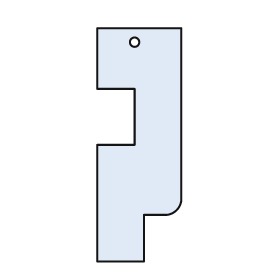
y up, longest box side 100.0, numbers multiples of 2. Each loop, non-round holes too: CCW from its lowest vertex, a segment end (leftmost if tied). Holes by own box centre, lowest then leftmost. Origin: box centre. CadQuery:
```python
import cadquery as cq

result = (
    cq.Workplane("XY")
    .moveTo(-18.0, -50.0)
    .lineTo(2.0, -50.0)
    .lineTo(2.0, -30.0)
    .lineTo(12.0, -30.0)
    .threePointArc((16.0, -28.0), (18.0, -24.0))
    .lineTo(18.0, 50.0)
    .lineTo(-18.0, 50.0)
    .lineTo(-18.0, 24.0)
    .lineTo(-2.0, 24.0)
    .lineTo(-2.0, 0.0)
    .lineTo(-18.0, 0.0)
    .close()
    .moveTo(-2.0, 44.0)
    .circle(2.0)
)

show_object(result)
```